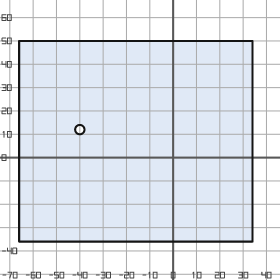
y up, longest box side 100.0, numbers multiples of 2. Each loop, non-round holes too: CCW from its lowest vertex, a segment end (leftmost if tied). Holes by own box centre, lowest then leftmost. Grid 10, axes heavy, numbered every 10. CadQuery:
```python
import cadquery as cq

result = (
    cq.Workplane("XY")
    .moveTo(-66.0, -36.0)
    .lineTo(34.0, -36.0)
    .lineTo(34.0, 50.0)
    .lineTo(-66.0, 50.0)
    .close()
    .moveTo(-40.0, 12.0)
    .circle(2.0)
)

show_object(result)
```